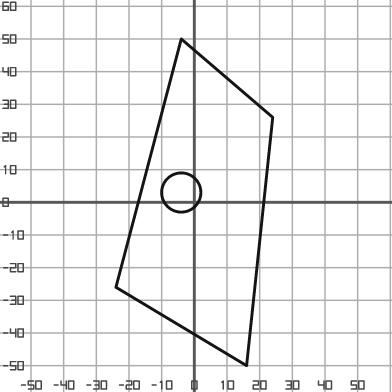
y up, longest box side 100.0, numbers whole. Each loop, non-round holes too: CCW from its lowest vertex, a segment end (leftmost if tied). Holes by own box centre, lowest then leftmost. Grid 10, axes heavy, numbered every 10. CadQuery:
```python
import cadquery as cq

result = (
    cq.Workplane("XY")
    .moveTo(16.0, -50.0)
    .lineTo(24.0, 26.0)
    .lineTo(-4.0, 50.0)
    .lineTo(-24.0, -26.0)
    .close()
    .moveTo(-4.0, 3.0)
    .circle(6.0)
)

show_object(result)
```